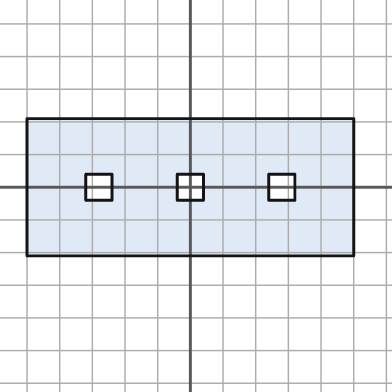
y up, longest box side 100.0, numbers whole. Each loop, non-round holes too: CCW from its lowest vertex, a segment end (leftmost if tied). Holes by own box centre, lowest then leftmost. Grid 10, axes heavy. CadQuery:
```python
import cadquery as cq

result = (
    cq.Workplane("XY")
    .moveTo(-50.0, -21.0)
    .lineTo(50.0, -21.0)
    .lineTo(50.0, 21.0)
    .lineTo(-50.0, 21.0)
    .close()
    .moveTo(-32.0, -4.0)
    .lineTo(-24.0, -4.0)
    .lineTo(-24.0, 4.0)
    .lineTo(-32.0, 4.0)
    .close()
    .moveTo(-4.0, -4.0)
    .lineTo(4.0, -4.0)
    .lineTo(4.0, 4.0)
    .lineTo(-4.0, 4.0)
    .close()
    .moveTo(24.0, -4.0)
    .lineTo(32.0, -4.0)
    .lineTo(32.0, 4.0)
    .lineTo(24.0, 4.0)
    .close()
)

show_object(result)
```